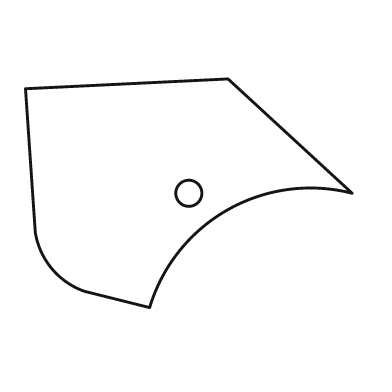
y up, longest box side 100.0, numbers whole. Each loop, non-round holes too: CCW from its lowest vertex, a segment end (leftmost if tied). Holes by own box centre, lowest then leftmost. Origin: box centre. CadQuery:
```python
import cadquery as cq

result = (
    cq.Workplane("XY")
    .moveTo(-12.0, -35.0)
    .threePointArc((12.0, -5.0), (50.0, 0.0))
    .lineTo(12.0, 35.0)
    .lineTo(-50.0, 32.0)
    .lineTo(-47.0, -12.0)
    .threePointArc((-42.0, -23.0), (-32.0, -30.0))
    .close()
    .moveTo(0.0, 0.0)
    .circle(4.0)
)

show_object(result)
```